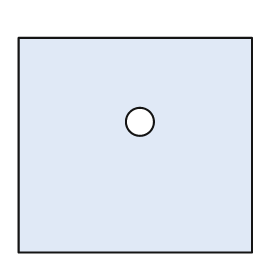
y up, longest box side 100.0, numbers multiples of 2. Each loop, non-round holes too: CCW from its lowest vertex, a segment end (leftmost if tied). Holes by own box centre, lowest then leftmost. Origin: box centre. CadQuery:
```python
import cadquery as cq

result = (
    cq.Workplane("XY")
    .moveTo(-50.0, -46.0)
    .lineTo(50.0, -46.0)
    .lineTo(50.0, 46.0)
    .lineTo(-50.0, 46.0)
    .close()
    .moveTo(2.0, 10.0)
    .circle(6.0)
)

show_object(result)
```